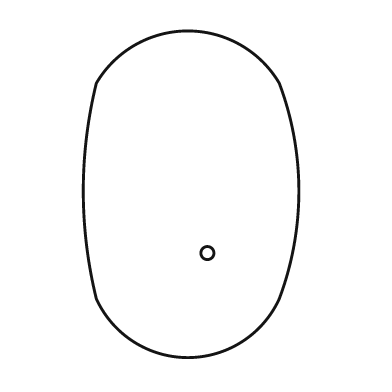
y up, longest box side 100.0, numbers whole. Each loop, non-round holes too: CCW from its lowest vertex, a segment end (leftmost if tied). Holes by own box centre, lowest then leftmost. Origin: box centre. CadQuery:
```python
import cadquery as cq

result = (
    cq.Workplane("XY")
    .moveTo(-29.0, -32.0)
    .threePointArc((-1.0, -50.0), (27.0, -32.0))
    .threePointArc((33.0, 1.0), (27.0, 34.0))
    .threePointArc((-1.0, 50.0), (-29.0, 34.0))
    .threePointArc((-33.0, 1.0), (-29.0, -32.0))
    .close()
    .moveTo(5.0, -18.0)
    .circle(2.0)
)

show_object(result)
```